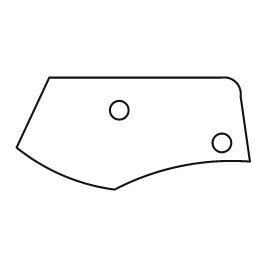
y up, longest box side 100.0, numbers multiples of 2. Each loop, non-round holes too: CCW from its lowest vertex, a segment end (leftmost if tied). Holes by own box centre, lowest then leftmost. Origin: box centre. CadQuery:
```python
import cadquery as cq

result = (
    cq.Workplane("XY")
    .moveTo(-8.0, -24.0)
    .threePointArc((20.0, -14.0), (50.0, -12.0))
    .lineTo(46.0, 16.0)
    .threePointArc((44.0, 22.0), (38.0, 24.0))
    .lineTo(-36.0, 24.0)
    .lineTo(-50.0, -6.0)
    .threePointArc((-30.0, -18.0), (-8.0, -24.0))
    .close()
    .moveTo(38.0, -4.0)
    .circle(4.0)
    .moveTo(-6.0, 10.0)
    .circle(4.0)
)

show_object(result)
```